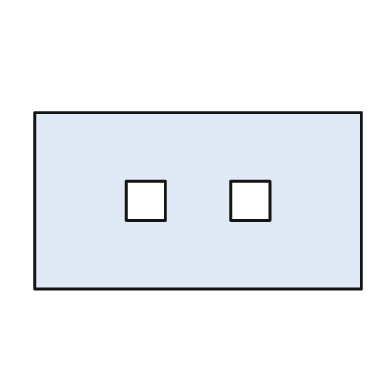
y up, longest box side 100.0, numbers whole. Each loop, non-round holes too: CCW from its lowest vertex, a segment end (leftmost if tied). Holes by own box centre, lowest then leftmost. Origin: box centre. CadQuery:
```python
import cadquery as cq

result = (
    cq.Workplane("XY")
    .moveTo(-50.0, -27.0)
    .lineTo(50.0, -27.0)
    .lineTo(50.0, 27.0)
    .lineTo(-50.0, 27.0)
    .close()
    .moveTo(-22.0, -6.0)
    .lineTo(-10.0, -6.0)
    .lineTo(-10.0, 6.0)
    .lineTo(-22.0, 6.0)
    .close()
    .moveTo(10.0, -6.0)
    .lineTo(22.0, -6.0)
    .lineTo(22.0, 6.0)
    .lineTo(10.0, 6.0)
    .close()
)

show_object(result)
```